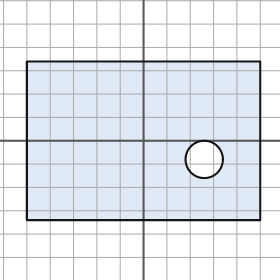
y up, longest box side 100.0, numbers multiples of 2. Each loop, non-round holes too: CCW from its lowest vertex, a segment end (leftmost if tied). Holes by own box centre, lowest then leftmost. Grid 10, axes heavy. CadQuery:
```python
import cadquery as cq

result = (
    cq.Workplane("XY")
    .moveTo(-50.0, -34.0)
    .lineTo(50.0, -34.0)
    .lineTo(50.0, 34.0)
    .lineTo(-50.0, 34.0)
    .close()
    .moveTo(26.0, -8.0)
    .circle(8.0)
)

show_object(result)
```